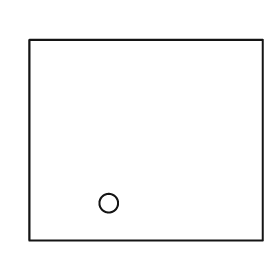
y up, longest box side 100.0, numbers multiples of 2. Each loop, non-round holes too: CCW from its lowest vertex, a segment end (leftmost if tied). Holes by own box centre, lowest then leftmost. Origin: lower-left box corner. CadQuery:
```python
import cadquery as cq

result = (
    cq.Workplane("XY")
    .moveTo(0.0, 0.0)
    .lineTo(100.0, 0.0)
    .lineTo(100.0, 86.0)
    .lineTo(0.0, 86.0)
    .close()
    .moveTo(34.0, 16.0)
    .circle(4.0)
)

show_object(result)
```